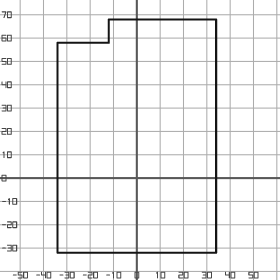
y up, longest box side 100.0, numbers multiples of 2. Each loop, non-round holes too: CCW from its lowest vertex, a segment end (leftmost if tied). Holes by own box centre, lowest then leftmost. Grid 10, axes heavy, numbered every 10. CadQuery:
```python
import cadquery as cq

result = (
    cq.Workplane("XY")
    .moveTo(-34.0, -32.0)
    .lineTo(34.0, -32.0)
    .lineTo(34.0, 68.0)
    .lineTo(-12.0, 68.0)
    .lineTo(-12.0, 58.0)
    .lineTo(-34.0, 58.0)
    .close()
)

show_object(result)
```